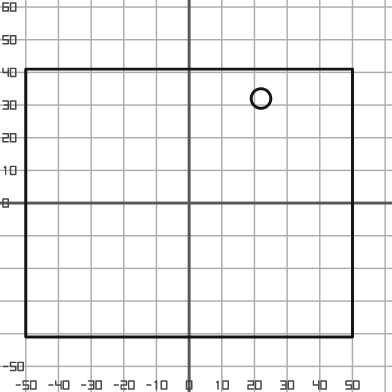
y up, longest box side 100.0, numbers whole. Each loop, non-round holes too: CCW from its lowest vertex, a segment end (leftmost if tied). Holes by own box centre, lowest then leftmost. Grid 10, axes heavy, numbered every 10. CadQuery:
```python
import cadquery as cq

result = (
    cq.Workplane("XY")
    .moveTo(-50.0, -41.0)
    .lineTo(50.0, -41.0)
    .lineTo(50.0, 41.0)
    .lineTo(-50.0, 41.0)
    .close()
    .moveTo(22.0, 32.0)
    .circle(3.0)
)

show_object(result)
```